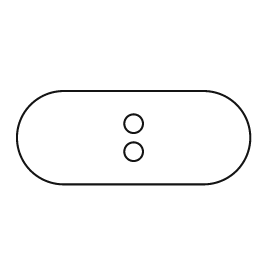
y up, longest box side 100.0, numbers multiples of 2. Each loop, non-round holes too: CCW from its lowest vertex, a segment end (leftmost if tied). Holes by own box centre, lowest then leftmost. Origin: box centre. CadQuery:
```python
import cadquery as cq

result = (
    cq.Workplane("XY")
    .moveTo(-30.0, -20.0)
    .lineTo(30.0, -20.0)
    .threePointArc((50.0, 0.0), (30.0, 20.0))
    .lineTo(-30.0, 20.0)
    .threePointArc((-50.0, 0.0), (-30.0, -20.0))
    .close()
    .moveTo(0.0, -6.0)
    .circle(4.0)
    .moveTo(0.0, 6.0)
    .circle(4.0)
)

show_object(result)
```